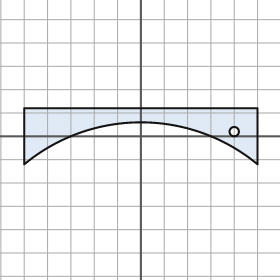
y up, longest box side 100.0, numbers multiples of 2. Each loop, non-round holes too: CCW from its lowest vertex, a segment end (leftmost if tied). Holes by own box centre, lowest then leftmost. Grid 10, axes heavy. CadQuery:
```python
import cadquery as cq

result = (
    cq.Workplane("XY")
    .moveTo(-50.0, -12.0)
    .threePointArc((0.0, 6.0), (50.0, -12.0))
    .lineTo(50.0, 12.0)
    .lineTo(-50.0, 12.0)
    .close()
    .moveTo(40.0, 2.0)
    .circle(2.0)
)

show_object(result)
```